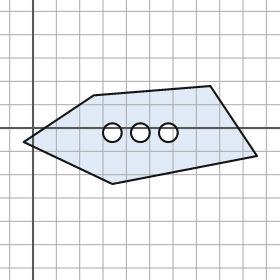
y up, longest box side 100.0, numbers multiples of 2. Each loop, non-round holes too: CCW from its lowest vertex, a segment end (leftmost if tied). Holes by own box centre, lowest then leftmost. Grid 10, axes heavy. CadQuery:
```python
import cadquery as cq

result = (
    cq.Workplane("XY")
    .moveTo(34.0, -24.0)
    .lineTo(96.0, -12.0)
    .lineTo(76.0, 18.0)
    .lineTo(26.0, 14.0)
    .lineTo(-4.0, -6.0)
    .close()
    .moveTo(34.0, -2.0)
    .circle(4.0)
    .moveTo(46.0, -2.0)
    .circle(4.0)
    .moveTo(58.0, -2.0)
    .circle(4.0)
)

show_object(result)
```